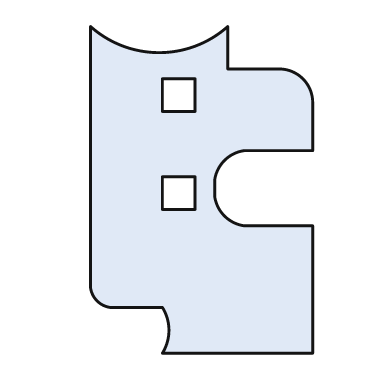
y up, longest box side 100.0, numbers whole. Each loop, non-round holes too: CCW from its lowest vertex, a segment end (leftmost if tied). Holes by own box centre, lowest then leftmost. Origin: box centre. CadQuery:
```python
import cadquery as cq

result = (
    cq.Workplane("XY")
    .moveTo(-12.0, -50.0)
    .lineTo(34.0, -50.0)
    .lineTo(34.0, -11.0)
    .lineTo(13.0, -11.0)
    .threePointArc((7.0, -8.0), (4.0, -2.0))
    .lineTo(4.0, 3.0)
    .threePointArc((7.0, 9.0), (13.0, 12.0))
    .lineTo(34.0, 12.0)
    .lineTo(34.0, 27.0)
    .threePointArc((31.0, 34.0), (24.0, 37.0))
    .lineTo(8.0, 37.0)
    .lineTo(8.0, 50.0)
    .threePointArc((-13.0, 42.0), (-34.0, 50.0))
    .lineTo(-34.0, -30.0)
    .threePointArc((-32.0, -34.0), (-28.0, -36.0))
    .lineTo(-12.0, -36.0)
    .threePointArc((-10.0, -43.0), (-12.0, -50.0))
    .close()
    .moveTo(-12.0, -6.0)
    .lineTo(-2.0, -6.0)
    .lineTo(-2.0, 4.0)
    .lineTo(-12.0, 4.0)
    .close()
    .moveTo(-12.0, 24.0)
    .lineTo(-2.0, 24.0)
    .lineTo(-2.0, 34.0)
    .lineTo(-12.0, 34.0)
    .close()
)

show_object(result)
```